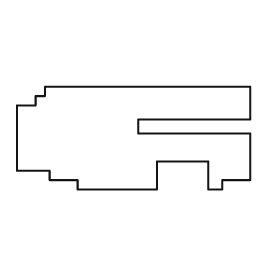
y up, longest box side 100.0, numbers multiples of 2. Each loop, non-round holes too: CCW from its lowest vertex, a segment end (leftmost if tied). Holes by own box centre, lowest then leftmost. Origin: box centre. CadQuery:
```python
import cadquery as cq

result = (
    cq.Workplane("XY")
    .moveTo(-24.0, -22.0)
    .lineTo(10.0, -22.0)
    .lineTo(10.0, -10.0)
    .lineTo(32.0, -10.0)
    .lineTo(32.0, -22.0)
    .lineTo(38.0, -22.0)
    .lineTo(38.0, -18.0)
    .lineTo(50.0, -18.0)
    .lineTo(50.0, 2.0)
    .lineTo(2.0, 2.0)
    .lineTo(2.0, 8.0)
    .lineTo(50.0, 8.0)
    .lineTo(50.0, 22.0)
    .lineTo(-38.0, 22.0)
    .lineTo(-38.0, 18.0)
    .lineTo(-42.0, 18.0)
    .lineTo(-42.0, 14.0)
    .lineTo(-50.0, 14.0)
    .lineTo(-50.0, -14.0)
    .lineTo(-36.0, -14.0)
    .lineTo(-36.0, -18.0)
    .lineTo(-24.0, -18.0)
    .close()
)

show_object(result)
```